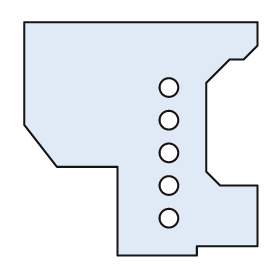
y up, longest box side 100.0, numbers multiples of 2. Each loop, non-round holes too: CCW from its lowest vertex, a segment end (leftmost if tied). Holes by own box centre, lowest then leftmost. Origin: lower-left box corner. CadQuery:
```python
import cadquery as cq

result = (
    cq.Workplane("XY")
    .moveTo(40.0, 0.0)
    .lineTo(74.0, 0.0)
    .lineTo(74.0, 4.0)
    .lineTo(100.0, 4.0)
    .lineTo(100.0, 30.0)
    .lineTo(84.0, 30.0)
    .lineTo(78.0, 36.0)
    .lineTo(78.0, 74.0)
    .lineTo(88.0, 84.0)
    .lineTo(94.0, 84.0)
    .lineTo(100.0, 90.0)
    .lineTo(100.0, 100.0)
    .lineTo(0.0, 100.0)
    .lineTo(0.0, 56.0)
    .lineTo(14.0, 38.0)
    .lineTo(40.0, 38.0)
    .close()
    .moveTo(62.0, 16.0)
    .circle(4.0)
    .moveTo(62.0, 30.0)
    .circle(4.0)
    .moveTo(62.0, 44.0)
    .circle(4.0)
    .moveTo(62.0, 58.0)
    .circle(4.0)
    .moveTo(62.0, 72.0)
    .circle(4.0)
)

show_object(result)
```